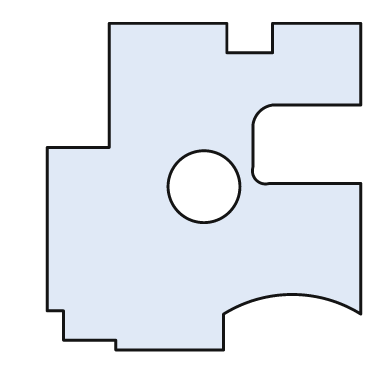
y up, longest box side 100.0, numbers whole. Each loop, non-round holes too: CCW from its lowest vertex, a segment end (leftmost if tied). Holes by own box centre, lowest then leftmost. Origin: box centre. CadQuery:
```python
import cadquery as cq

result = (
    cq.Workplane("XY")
    .moveTo(-27.0, -50.0)
    .lineTo(6.0, -50.0)
    .lineTo(6.0, -39.0)
    .threePointArc((27.0, -33.0), (48.0, -39.0))
    .lineTo(48.0, 1.0)
    .lineTo(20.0, 1.0)
    .threePointArc((16.0, 2.0), (15.0, 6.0))
    .lineTo(15.0, 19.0)
    .threePointArc((17.0, 23.0), (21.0, 25.0))
    .lineTo(48.0, 25.0)
    .lineTo(48.0, 50.0)
    .lineTo(21.0, 50.0)
    .lineTo(21.0, 41.0)
    .lineTo(7.0, 41.0)
    .lineTo(7.0, 50.0)
    .lineTo(-29.0, 50.0)
    .lineTo(-29.0, 12.0)
    .lineTo(-48.0, 12.0)
    .lineTo(-48.0, -38.0)
    .lineTo(-43.0, -38.0)
    .lineTo(-43.0, -47.0)
    .lineTo(-27.0, -47.0)
    .close()
    .moveTo(0.0, 0.0)
    .circle(11.0)
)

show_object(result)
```